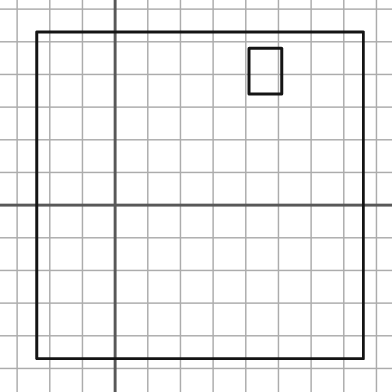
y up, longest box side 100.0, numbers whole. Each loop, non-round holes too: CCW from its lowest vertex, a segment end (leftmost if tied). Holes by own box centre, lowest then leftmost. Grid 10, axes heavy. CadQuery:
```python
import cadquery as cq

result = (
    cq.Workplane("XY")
    .moveTo(-24.0, -47.0)
    .lineTo(76.0, -47.0)
    .lineTo(76.0, 53.0)
    .lineTo(-24.0, 53.0)
    .close()
    .moveTo(41.0, 34.0)
    .lineTo(51.0, 34.0)
    .lineTo(51.0, 48.0)
    .lineTo(41.0, 48.0)
    .close()
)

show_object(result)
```